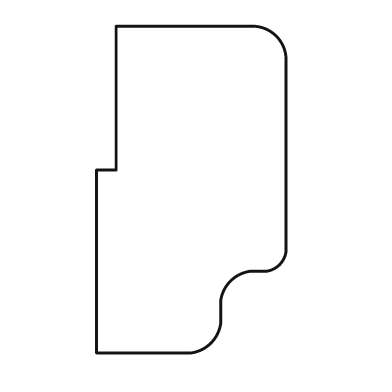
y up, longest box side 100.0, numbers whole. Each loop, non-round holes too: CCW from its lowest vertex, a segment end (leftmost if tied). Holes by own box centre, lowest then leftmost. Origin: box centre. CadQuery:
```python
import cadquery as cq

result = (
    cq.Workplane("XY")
    .moveTo(-29.0, -50.0)
    .lineTo(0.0, -50.0)
    .threePointArc((6.0, -47.0), (9.0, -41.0))
    .lineTo(9.0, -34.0)
    .threePointArc((12.0, -28.0), (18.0, -25.0))
    .lineTo(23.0, -25.0)
    .threePointArc((27.0, -23.0), (29.0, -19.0))
    .lineTo(29.0, 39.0)
    .threePointArc((26.0, 47.0), (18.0, 50.0))
    .lineTo(-23.0, 50.0)
    .lineTo(-23.0, 6.0)
    .lineTo(-29.0, 6.0)
    .close()
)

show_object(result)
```